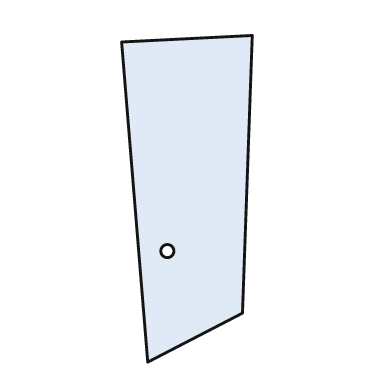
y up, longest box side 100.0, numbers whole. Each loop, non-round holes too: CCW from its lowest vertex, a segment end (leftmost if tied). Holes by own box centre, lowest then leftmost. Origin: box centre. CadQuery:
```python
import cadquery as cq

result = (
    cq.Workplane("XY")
    .moveTo(-12.0, -50.0)
    .lineTo(17.0, -35.0)
    .lineTo(20.0, 50.0)
    .lineTo(-20.0, 48.0)
    .close()
    .moveTo(-6.0, -16.0)
    .circle(2.0)
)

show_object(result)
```